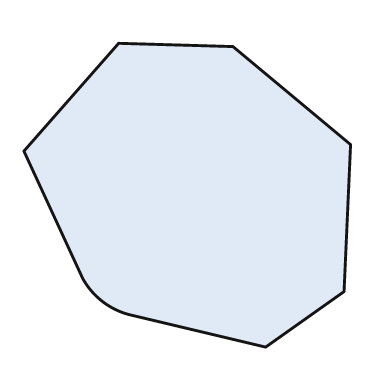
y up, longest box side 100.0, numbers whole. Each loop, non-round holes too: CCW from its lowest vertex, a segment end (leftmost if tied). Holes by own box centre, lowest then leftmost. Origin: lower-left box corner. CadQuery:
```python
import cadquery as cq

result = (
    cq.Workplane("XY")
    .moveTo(74.0, 0.0)
    .lineTo(98.0, 17.0)
    .lineTo(100.0, 62.0)
    .lineTo(64.0, 92.0)
    .lineTo(29.0, 93.0)
    .lineTo(0.0, 60.0)
    .lineTo(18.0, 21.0)
    .threePointArc((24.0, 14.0), (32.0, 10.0))
    .close()
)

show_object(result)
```